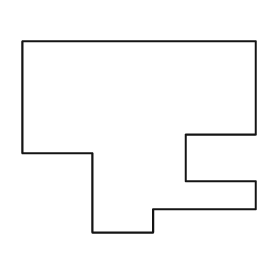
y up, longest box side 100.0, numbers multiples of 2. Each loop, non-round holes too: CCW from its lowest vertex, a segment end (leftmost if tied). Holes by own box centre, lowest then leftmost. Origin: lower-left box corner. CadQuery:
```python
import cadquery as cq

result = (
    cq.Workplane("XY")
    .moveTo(30.0, 0.0)
    .lineTo(56.0, 0.0)
    .lineTo(56.0, 10.0)
    .lineTo(100.0, 10.0)
    .lineTo(100.0, 22.0)
    .lineTo(70.0, 22.0)
    .lineTo(70.0, 42.0)
    .lineTo(100.0, 42.0)
    .lineTo(100.0, 82.0)
    .lineTo(0.0, 82.0)
    .lineTo(0.0, 34.0)
    .lineTo(30.0, 34.0)
    .close()
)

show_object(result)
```